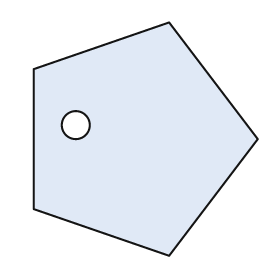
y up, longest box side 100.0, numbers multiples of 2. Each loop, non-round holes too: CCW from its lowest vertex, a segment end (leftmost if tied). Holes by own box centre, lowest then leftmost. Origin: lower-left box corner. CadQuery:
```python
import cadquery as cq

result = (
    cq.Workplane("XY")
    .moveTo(58.0, 0.0)
    .lineTo(96.0, 50.0)
    .lineTo(58.0, 100.0)
    .lineTo(0.0, 80.0)
    .lineTo(0.0, 20.0)
    .close()
    .moveTo(18.0, 56.0)
    .circle(6.0)
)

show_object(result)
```